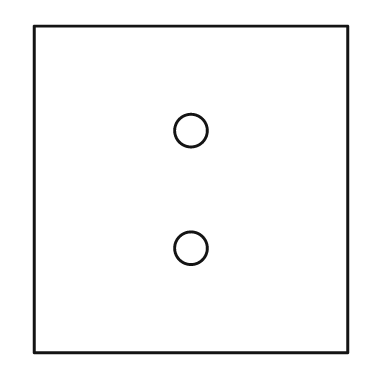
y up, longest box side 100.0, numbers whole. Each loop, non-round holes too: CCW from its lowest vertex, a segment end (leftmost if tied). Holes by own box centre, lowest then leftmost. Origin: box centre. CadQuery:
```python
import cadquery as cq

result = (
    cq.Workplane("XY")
    .moveTo(-48.0, -50.0)
    .lineTo(48.0, -50.0)
    .lineTo(48.0, 50.0)
    .lineTo(-48.0, 50.0)
    .close()
    .moveTo(0.0, -18.0)
    .circle(5.0)
    .moveTo(0.0, 18.0)
    .circle(5.0)
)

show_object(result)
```